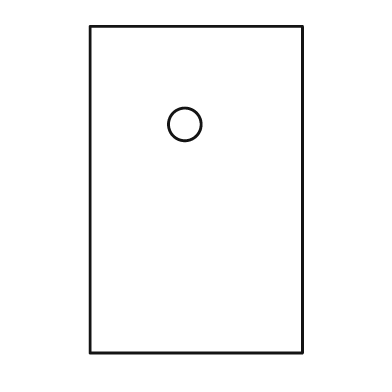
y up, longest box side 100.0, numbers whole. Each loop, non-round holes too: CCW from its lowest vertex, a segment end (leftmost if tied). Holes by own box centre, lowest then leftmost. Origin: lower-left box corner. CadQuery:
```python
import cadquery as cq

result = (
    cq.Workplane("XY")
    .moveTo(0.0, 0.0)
    .lineTo(65.0, 0.0)
    .lineTo(65.0, 100.0)
    .lineTo(0.0, 100.0)
    .close()
    .moveTo(29.0, 70.0)
    .circle(5.0)
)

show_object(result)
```